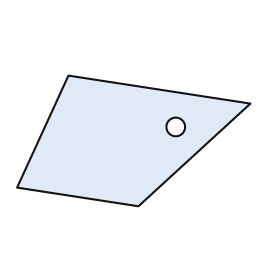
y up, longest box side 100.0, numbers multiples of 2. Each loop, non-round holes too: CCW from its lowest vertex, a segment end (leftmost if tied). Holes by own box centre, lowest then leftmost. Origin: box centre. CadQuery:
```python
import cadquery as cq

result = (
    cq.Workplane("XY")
    .moveTo(2.0, -28.0)
    .lineTo(50.0, 16.0)
    .lineTo(-28.0, 28.0)
    .lineTo(-50.0, -20.0)
    .close()
    .moveTo(18.0, 6.0)
    .circle(4.0)
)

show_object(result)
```